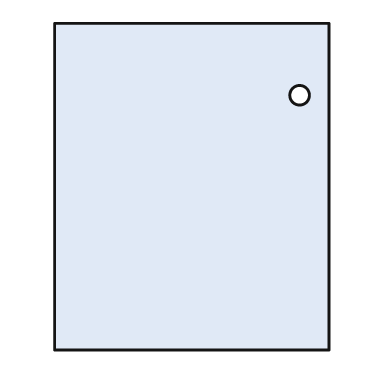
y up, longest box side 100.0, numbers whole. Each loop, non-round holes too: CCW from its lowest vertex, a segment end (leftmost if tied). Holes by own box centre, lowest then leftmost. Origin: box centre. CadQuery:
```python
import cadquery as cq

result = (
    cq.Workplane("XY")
    .moveTo(-42.0, -50.0)
    .lineTo(42.0, -50.0)
    .lineTo(42.0, 50.0)
    .lineTo(-42.0, 50.0)
    .close()
    .moveTo(33.0, 28.0)
    .circle(3.0)
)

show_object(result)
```